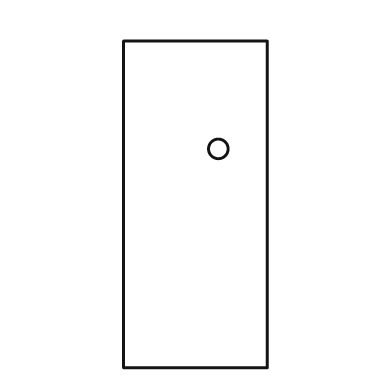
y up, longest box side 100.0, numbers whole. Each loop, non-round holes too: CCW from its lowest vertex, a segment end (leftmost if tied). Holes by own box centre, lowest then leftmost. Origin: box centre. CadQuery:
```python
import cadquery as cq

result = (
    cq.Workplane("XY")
    .moveTo(-22.0, -50.0)
    .lineTo(22.0, -50.0)
    .lineTo(22.0, 50.0)
    .lineTo(-22.0, 50.0)
    .close()
    .moveTo(7.0, 17.0)
    .circle(3.0)
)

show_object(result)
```